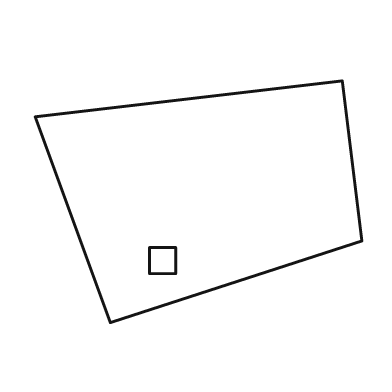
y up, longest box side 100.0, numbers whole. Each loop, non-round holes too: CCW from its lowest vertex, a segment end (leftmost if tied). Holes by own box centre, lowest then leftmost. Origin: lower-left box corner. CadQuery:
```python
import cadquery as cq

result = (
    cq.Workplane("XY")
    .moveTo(23.0, 0.0)
    .lineTo(100.0, 25.0)
    .lineTo(94.0, 74.0)
    .lineTo(0.0, 63.0)
    .close()
    .moveTo(35.0, 15.0)
    .lineTo(43.0, 15.0)
    .lineTo(43.0, 23.0)
    .lineTo(35.0, 23.0)
    .close()
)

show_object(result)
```